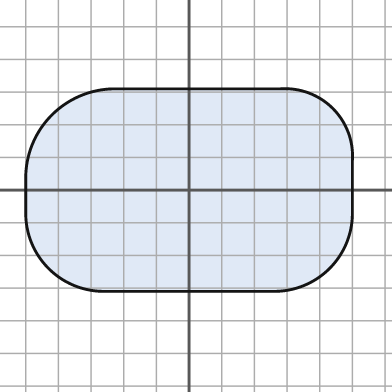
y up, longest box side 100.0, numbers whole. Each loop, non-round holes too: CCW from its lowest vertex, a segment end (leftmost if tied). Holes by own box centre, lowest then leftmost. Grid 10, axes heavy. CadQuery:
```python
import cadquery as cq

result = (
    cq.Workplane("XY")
    .moveTo(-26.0, -31.0)
    .lineTo(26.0, -31.0)
    .threePointArc((43.0, -24.0), (50.0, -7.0))
    .lineTo(50.0, 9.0)
    .threePointArc((44.0, 25.0), (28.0, 31.0))
    .lineTo(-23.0, 31.0)
    .threePointArc((-42.0, 23.0), (-50.0, 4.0))
    .lineTo(-50.0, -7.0)
    .threePointArc((-43.0, -24.0), (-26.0, -31.0))
    .close()
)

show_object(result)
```